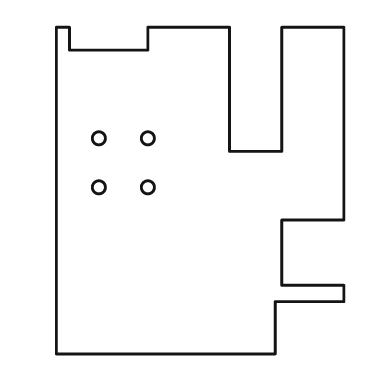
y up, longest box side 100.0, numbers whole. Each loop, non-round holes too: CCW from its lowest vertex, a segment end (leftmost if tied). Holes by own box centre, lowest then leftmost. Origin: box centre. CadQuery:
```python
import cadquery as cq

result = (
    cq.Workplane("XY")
    .moveTo(-44.0, -50.0)
    .lineTo(23.0, -50.0)
    .lineTo(23.0, -34.0)
    .lineTo(44.0, -34.0)
    .lineTo(44.0, -29.0)
    .lineTo(25.0, -29.0)
    .lineTo(25.0, -9.0)
    .lineTo(44.0, -9.0)
    .lineTo(44.0, 50.0)
    .lineTo(25.0, 50.0)
    .lineTo(25.0, 12.0)
    .lineTo(9.0, 12.0)
    .lineTo(9.0, 50.0)
    .lineTo(-16.0, 50.0)
    .lineTo(-16.0, 43.0)
    .lineTo(-40.0, 43.0)
    .lineTo(-40.0, 50.0)
    .lineTo(-44.0, 50.0)
    .close()
    .moveTo(-31.0, 1.0)
    .circle(2.0)
    .moveTo(-16.0, 1.0)
    .circle(2.0)
    .moveTo(-31.0, 16.0)
    .circle(2.0)
    .moveTo(-16.0, 16.0)
    .circle(2.0)
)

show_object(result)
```